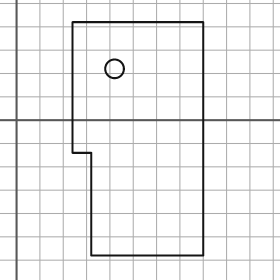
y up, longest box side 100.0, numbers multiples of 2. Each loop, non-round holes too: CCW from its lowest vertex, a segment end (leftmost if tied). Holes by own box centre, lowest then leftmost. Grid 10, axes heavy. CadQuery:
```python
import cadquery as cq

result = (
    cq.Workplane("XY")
    .moveTo(32.0, -58.0)
    .lineTo(80.0, -58.0)
    .lineTo(80.0, 42.0)
    .lineTo(24.0, 42.0)
    .lineTo(24.0, -14.0)
    .lineTo(32.0, -14.0)
    .close()
    .moveTo(42.0, 22.0)
    .circle(4.0)
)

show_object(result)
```